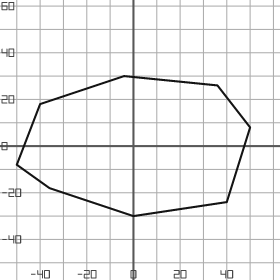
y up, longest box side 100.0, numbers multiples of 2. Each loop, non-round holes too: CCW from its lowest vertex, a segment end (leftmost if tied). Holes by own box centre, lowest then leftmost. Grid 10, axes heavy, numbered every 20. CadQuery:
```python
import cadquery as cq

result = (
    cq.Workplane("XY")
    .moveTo(0.0, -30.0)
    .lineTo(40.0, -24.0)
    .lineTo(50.0, 8.0)
    .lineTo(36.0, 26.0)
    .lineTo(-4.0, 30.0)
    .lineTo(-40.0, 18.0)
    .lineTo(-50.0, -8.0)
    .lineTo(-36.0, -18.0)
    .close()
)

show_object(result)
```